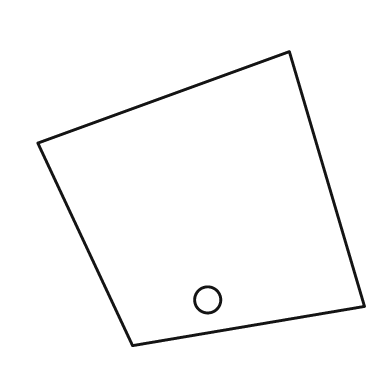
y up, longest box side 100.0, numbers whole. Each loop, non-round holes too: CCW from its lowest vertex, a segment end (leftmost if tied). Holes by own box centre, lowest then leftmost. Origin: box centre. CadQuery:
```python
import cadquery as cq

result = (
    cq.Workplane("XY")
    .moveTo(-21.0, -45.0)
    .lineTo(50.0, -33.0)
    .lineTo(27.0, 45.0)
    .lineTo(-50.0, 17.0)
    .close()
    .moveTo(2.0, -31.0)
    .circle(4.0)
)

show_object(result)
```